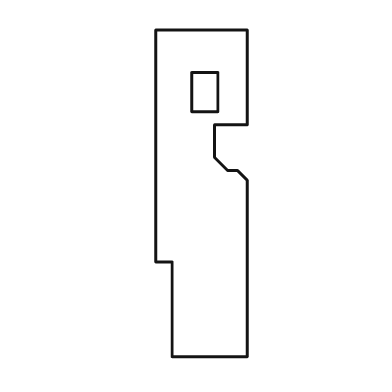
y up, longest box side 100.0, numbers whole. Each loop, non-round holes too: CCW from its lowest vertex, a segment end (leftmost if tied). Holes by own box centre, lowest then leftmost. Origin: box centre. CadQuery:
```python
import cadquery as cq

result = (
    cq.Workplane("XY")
    .moveTo(-9.0, -50.0)
    .lineTo(14.0, -50.0)
    .lineTo(14.0, 4.0)
    .lineTo(11.0, 7.0)
    .lineTo(8.0, 7.0)
    .lineTo(4.0, 11.0)
    .lineTo(4.0, 21.0)
    .lineTo(14.0, 21.0)
    .lineTo(14.0, 50.0)
    .lineTo(-14.0, 50.0)
    .lineTo(-14.0, -21.0)
    .lineTo(-9.0, -21.0)
    .close()
    .moveTo(-3.0, 25.0)
    .lineTo(5.0, 25.0)
    .lineTo(5.0, 37.0)
    .lineTo(-3.0, 37.0)
    .close()
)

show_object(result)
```